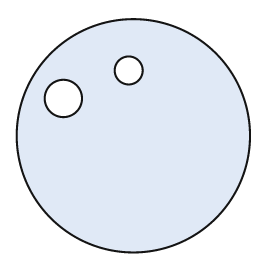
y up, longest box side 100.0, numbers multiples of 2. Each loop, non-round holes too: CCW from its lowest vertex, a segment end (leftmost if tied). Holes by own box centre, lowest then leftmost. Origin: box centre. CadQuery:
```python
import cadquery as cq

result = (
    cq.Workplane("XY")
    .moveTo(0.0, 0.0)
    .circle(50.0)
    .moveTo(-30.0, 16.0)
    .circle(8.0)
    .moveTo(-2.0, 28.0)
    .circle(6.0)
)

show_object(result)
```